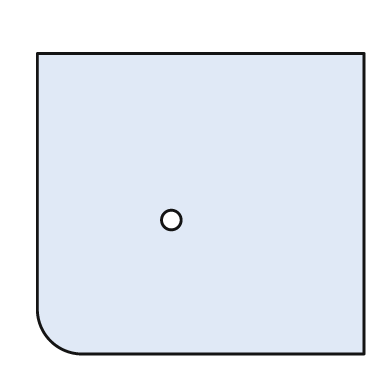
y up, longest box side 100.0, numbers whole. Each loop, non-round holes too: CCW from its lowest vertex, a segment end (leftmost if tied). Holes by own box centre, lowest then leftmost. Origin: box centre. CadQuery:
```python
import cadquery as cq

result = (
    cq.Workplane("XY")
    .moveTo(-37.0, -46.0)
    .lineTo(50.0, -46.0)
    .lineTo(50.0, 46.0)
    .lineTo(-50.0, 46.0)
    .lineTo(-50.0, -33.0)
    .threePointArc((-46.0, -42.0), (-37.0, -46.0))
    .close()
    .moveTo(-9.0, -5.0)
    .circle(3.0)
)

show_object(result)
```